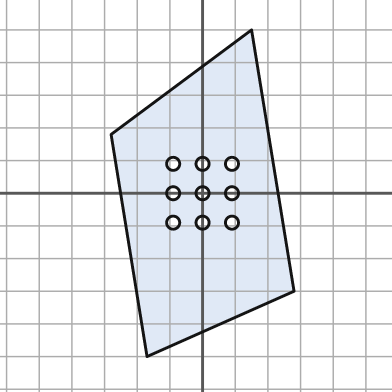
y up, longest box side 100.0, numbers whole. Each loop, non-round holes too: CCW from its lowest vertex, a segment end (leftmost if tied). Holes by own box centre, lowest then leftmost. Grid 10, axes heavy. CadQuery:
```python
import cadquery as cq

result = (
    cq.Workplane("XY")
    .moveTo(-17.0, -50.0)
    .lineTo(28.0, -30.0)
    .lineTo(15.0, 50.0)
    .lineTo(-28.0, 18.0)
    .close()
    .moveTo(-9.0, -9.0)
    .circle(2.0)
    .moveTo(0.0, -9.0)
    .circle(2.0)
    .moveTo(9.0, -9.0)
    .circle(2.0)
    .moveTo(-9.0, 0.0)
    .circle(2.0)
    .moveTo(0.0, 0.0)
    .circle(2.0)
    .moveTo(9.0, 0.0)
    .circle(2.0)
    .moveTo(-9.0, 9.0)
    .circle(2.0)
    .moveTo(0.0, 9.0)
    .circle(2.0)
    .moveTo(9.0, 9.0)
    .circle(2.0)
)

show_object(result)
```